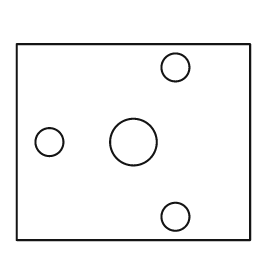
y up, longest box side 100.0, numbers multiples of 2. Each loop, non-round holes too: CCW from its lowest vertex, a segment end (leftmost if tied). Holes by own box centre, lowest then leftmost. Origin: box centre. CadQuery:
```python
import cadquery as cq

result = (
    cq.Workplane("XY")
    .moveTo(-50.0, -42.0)
    .lineTo(50.0, -42.0)
    .lineTo(50.0, 42.0)
    .lineTo(-50.0, 42.0)
    .close()
    .moveTo(18.0, -32.0)
    .circle(6.0)
    .moveTo(-36.0, 0.0)
    .circle(6.0)
    .moveTo(0.0, 0.0)
    .circle(10.0)
    .moveTo(18.0, 32.0)
    .circle(6.0)
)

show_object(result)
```